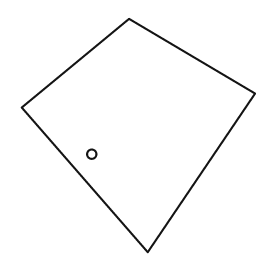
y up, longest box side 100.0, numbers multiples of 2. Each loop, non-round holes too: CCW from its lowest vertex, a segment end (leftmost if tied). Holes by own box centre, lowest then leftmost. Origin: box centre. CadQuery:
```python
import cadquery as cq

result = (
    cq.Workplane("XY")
    .moveTo(4.0, -50.0)
    .lineTo(50.0, 18.0)
    .lineTo(-4.0, 50.0)
    .lineTo(-50.0, 12.0)
    .close()
    .moveTo(-20.0, -8.0)
    .circle(2.0)
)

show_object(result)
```